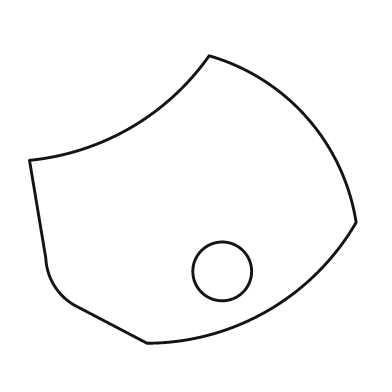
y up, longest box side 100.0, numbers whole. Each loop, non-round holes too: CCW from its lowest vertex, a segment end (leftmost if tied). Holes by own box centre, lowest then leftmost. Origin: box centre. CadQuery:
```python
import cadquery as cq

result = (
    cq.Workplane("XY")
    .moveTo(-14.0, -44.0)
    .threePointArc((23.0, -34.0), (50.0, -7.0))
    .threePointArc((35.0, 25.0), (5.0, 44.0))
    .threePointArc((-19.0, 22.0), (-50.0, 12.0))
    .lineTo(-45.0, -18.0)
    .threePointArc((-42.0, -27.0), (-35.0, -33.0))
    .close()
    .moveTo(9.0, -22.0)
    .circle(9.0)
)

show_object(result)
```